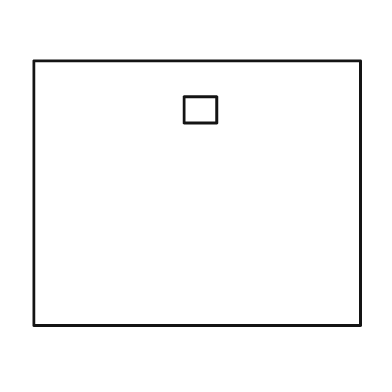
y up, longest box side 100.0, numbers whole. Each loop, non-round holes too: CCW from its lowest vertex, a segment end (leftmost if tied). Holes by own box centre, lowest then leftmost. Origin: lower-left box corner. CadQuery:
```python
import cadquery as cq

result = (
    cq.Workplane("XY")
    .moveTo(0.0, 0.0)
    .lineTo(100.0, 0.0)
    .lineTo(100.0, 81.0)
    .lineTo(0.0, 81.0)
    .close()
    .moveTo(46.0, 62.0)
    .lineTo(56.0, 62.0)
    .lineTo(56.0, 70.0)
    .lineTo(46.0, 70.0)
    .close()
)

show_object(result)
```